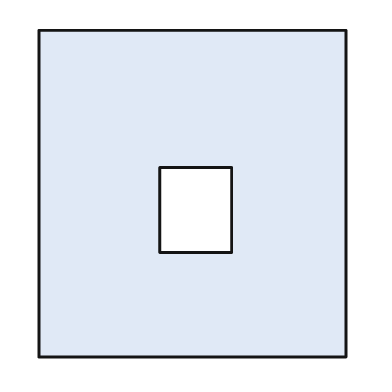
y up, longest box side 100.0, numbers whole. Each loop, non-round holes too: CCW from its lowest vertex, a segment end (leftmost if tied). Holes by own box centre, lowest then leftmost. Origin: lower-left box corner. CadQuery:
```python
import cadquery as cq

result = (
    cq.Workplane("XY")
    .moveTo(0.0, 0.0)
    .lineTo(94.0, 0.0)
    .lineTo(94.0, 100.0)
    .lineTo(0.0, 100.0)
    .close()
    .moveTo(37.0, 32.0)
    .lineTo(59.0, 32.0)
    .lineTo(59.0, 58.0)
    .lineTo(37.0, 58.0)
    .close()
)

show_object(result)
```